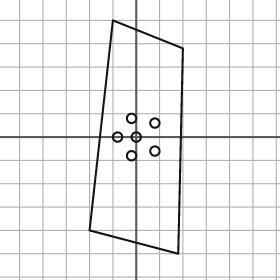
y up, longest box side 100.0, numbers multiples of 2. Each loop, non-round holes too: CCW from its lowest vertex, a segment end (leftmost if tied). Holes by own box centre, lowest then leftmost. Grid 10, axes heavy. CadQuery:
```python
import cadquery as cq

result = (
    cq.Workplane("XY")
    .moveTo(18.0, -50.0)
    .lineTo(20.0, 38.0)
    .lineTo(-10.0, 50.0)
    .lineTo(-20.0, -40.0)
    .close()
    .moveTo(-2.0, -8.0)
    .circle(2.0)
    .moveTo(8.0, -6.0)
    .circle(2.0)
    .moveTo(-8.0, 0.0)
    .circle(2.0)
    .moveTo(0.0, 0.0)
    .circle(2.0)
    .moveTo(8.0, 6.0)
    .circle(2.0)
    .moveTo(-2.0, 8.0)
    .circle(2.0)
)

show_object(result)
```